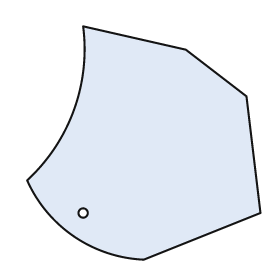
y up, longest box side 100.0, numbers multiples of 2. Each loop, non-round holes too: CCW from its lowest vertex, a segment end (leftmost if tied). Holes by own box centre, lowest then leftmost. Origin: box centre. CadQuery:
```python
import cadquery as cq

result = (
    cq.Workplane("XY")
    .moveTo(0.0, -50.0)
    .lineTo(50.0, -30.0)
    .lineTo(44.0, 20.0)
    .lineTo(18.0, 40.0)
    .lineTo(-26.0, 50.0)
    .threePointArc((-30.0, 14.0), (-50.0, -16.0))
    .threePointArc((-30.0, -40.0), (0.0, -50.0))
    .close()
    .moveTo(-26.0, -30.0)
    .circle(2.0)
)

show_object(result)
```